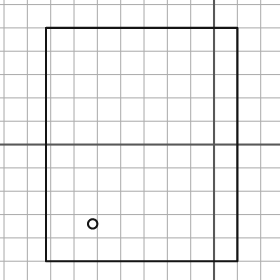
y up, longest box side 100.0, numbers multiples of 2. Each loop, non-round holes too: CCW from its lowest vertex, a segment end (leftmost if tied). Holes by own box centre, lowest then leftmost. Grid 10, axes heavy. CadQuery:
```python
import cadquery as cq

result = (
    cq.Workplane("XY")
    .moveTo(-72.0, -50.0)
    .lineTo(10.0, -50.0)
    .lineTo(10.0, 50.0)
    .lineTo(-72.0, 50.0)
    .close()
    .moveTo(-52.0, -34.0)
    .circle(2.0)
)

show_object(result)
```